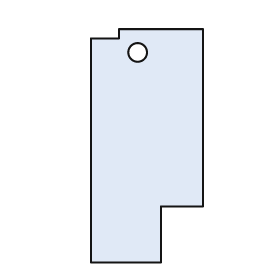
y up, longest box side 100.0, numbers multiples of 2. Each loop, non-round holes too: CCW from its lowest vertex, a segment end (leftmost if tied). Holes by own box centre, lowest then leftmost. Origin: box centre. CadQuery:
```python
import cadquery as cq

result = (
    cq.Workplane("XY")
    .moveTo(-24.0, -50.0)
    .lineTo(6.0, -50.0)
    .lineTo(6.0, -26.0)
    .lineTo(24.0, -26.0)
    .lineTo(24.0, 50.0)
    .lineTo(-12.0, 50.0)
    .lineTo(-12.0, 46.0)
    .lineTo(-24.0, 46.0)
    .close()
    .moveTo(-4.0, 40.0)
    .circle(4.0)
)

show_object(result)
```